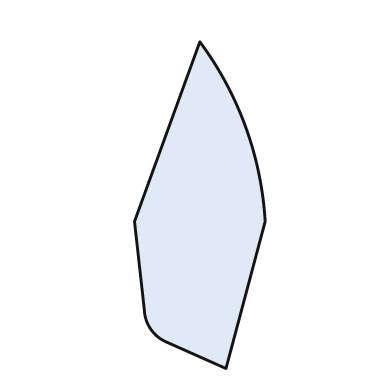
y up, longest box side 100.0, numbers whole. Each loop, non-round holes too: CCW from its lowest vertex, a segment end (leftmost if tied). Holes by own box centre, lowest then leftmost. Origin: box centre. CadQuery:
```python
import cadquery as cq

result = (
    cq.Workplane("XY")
    .moveTo(8.0, -50.0)
    .lineTo(20.0, -5.0)
    .threePointArc((14.0, 24.0), (0.0, 50.0))
    .lineTo(-20.0, -5.0)
    .lineTo(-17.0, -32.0)
    .threePointArc((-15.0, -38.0), (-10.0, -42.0))
    .close()
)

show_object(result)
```